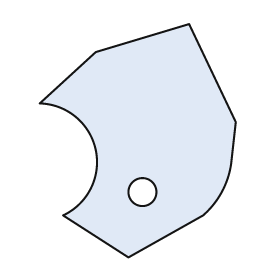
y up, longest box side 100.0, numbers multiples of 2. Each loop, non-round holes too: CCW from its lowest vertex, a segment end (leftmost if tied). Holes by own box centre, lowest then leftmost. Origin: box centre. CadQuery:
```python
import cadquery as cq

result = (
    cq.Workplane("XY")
    .moveTo(-4.0, -50.0)
    .lineTo(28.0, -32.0)
    .threePointArc((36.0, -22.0), (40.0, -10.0))
    .lineTo(42.0, 8.0)
    .lineTo(22.0, 50.0)
    .lineTo(-18.0, 38.0)
    .lineTo(-42.0, 16.0)
    .threePointArc((-18.0, -4.0), (-32.0, -32.0))
    .close()
    .moveTo(2.0, -22.0)
    .circle(6.0)
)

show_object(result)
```